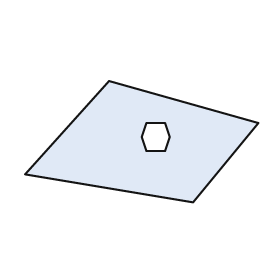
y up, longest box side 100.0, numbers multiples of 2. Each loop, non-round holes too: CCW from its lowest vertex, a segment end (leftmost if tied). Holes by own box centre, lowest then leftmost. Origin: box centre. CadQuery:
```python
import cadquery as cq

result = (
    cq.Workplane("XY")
    .moveTo(22.0, -26.0)
    .lineTo(50.0, 8.0)
    .lineTo(-14.0, 26.0)
    .lineTo(-50.0, -14.0)
    .close()
    .moveTo(2.0, -4.0)
    .lineTo(10.0, -4.0)
    .lineTo(12.0, 2.0)
    .lineTo(10.0, 8.0)
    .lineTo(2.0, 8.0)
    .lineTo(0.0, 2.0)
    .close()
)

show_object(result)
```